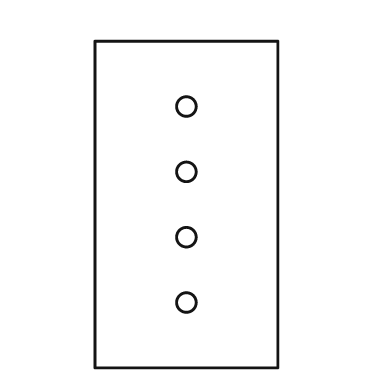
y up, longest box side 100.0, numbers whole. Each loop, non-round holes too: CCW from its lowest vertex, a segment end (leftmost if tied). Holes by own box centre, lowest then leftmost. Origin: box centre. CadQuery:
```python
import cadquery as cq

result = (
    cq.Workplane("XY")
    .moveTo(-28.0, -50.0)
    .lineTo(28.0, -50.0)
    .lineTo(28.0, 50.0)
    .lineTo(-28.0, 50.0)
    .close()
    .moveTo(0.0, -30.0)
    .circle(3.0)
    .moveTo(0.0, -10.0)
    .circle(3.0)
    .moveTo(0.0, 10.0)
    .circle(3.0)
    .moveTo(0.0, 30.0)
    .circle(3.0)
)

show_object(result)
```